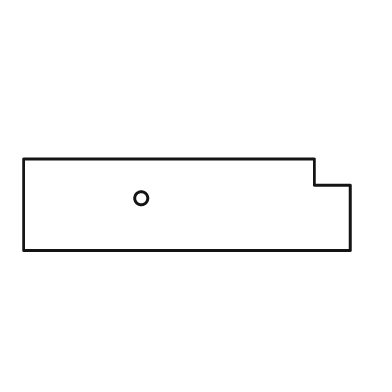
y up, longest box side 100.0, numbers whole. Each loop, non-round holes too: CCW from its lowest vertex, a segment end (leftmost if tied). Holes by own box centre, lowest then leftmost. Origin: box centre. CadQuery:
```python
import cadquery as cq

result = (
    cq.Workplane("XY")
    .moveTo(-50.0, -14.0)
    .lineTo(50.0, -14.0)
    .lineTo(50.0, 6.0)
    .lineTo(39.0, 6.0)
    .lineTo(39.0, 14.0)
    .lineTo(-50.0, 14.0)
    .close()
    .moveTo(-14.0, 2.0)
    .circle(2.0)
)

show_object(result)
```